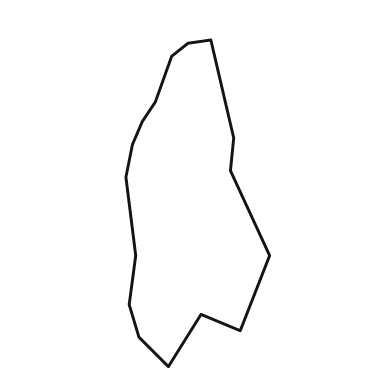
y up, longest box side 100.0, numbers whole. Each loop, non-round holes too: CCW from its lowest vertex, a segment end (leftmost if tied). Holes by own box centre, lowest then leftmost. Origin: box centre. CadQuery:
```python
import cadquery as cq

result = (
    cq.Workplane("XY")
    .moveTo(-9.0, -50.0)
    .lineTo(1.0, -34.0)
    .lineTo(13.0, -39.0)
    .lineTo(22.0, -16.0)
    .lineTo(10.0, 10.0)
    .lineTo(11.0, 20.0)
    .lineTo(4.0, 50.0)
    .lineTo(-3.0, 49.0)
    .lineTo(-8.0, 45.0)
    .lineTo(-13.0, 31.0)
    .lineTo(-17.0, 25.0)
    .lineTo(-20.0, 18.0)
    .lineTo(-22.0, 8.0)
    .lineTo(-19.0, -16.0)
    .lineTo(-21.0, -31.0)
    .lineTo(-18.0, -41.0)
    .close()
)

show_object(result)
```